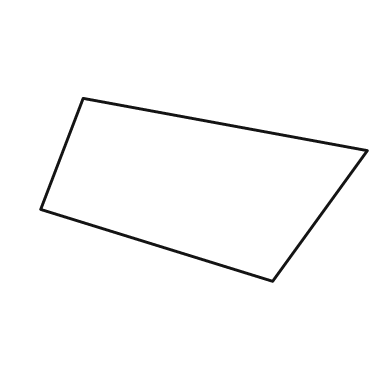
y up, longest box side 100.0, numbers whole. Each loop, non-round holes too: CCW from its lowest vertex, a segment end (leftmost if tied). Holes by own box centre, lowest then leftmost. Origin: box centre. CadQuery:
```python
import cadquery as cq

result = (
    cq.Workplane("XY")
    .moveTo(21.0, -28.0)
    .lineTo(50.0, 12.0)
    .lineTo(-37.0, 28.0)
    .lineTo(-50.0, -6.0)
    .close()
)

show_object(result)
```